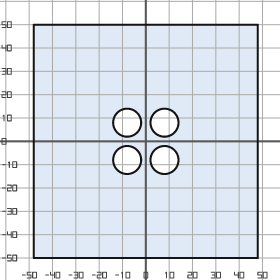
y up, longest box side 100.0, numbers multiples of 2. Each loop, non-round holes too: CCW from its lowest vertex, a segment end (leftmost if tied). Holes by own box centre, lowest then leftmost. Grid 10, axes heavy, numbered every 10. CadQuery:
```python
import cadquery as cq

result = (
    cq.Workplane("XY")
    .moveTo(-48.0, -50.0)
    .lineTo(48.0, -50.0)
    .lineTo(48.0, 50.0)
    .lineTo(-48.0, 50.0)
    .close()
    .moveTo(-8.0, -8.0)
    .circle(6.0)
    .moveTo(8.0, -8.0)
    .circle(6.0)
    .moveTo(-8.0, 8.0)
    .circle(6.0)
    .moveTo(8.0, 8.0)
    .circle(6.0)
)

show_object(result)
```